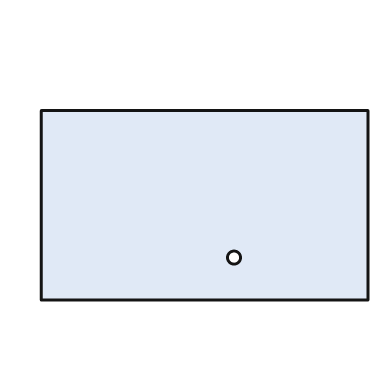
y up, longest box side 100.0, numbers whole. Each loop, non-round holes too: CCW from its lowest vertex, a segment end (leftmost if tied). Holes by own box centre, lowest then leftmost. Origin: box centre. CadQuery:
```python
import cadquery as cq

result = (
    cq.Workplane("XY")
    .moveTo(-50.0, -29.0)
    .lineTo(50.0, -29.0)
    .lineTo(50.0, 29.0)
    .lineTo(-50.0, 29.0)
    .close()
    .moveTo(9.0, -16.0)
    .circle(2.0)
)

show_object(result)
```